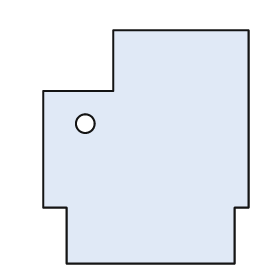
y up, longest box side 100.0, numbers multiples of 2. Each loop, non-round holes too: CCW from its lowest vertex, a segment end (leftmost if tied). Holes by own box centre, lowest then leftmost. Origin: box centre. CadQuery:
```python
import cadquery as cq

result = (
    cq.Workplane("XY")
    .moveTo(-34.0, -50.0)
    .lineTo(38.0, -50.0)
    .lineTo(38.0, -26.0)
    .lineTo(44.0, -26.0)
    .lineTo(44.0, 50.0)
    .lineTo(-14.0, 50.0)
    .lineTo(-14.0, 24.0)
    .lineTo(-44.0, 24.0)
    .lineTo(-44.0, -26.0)
    .lineTo(-34.0, -26.0)
    .close()
    .moveTo(-26.0, 10.0)
    .circle(4.0)
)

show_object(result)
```